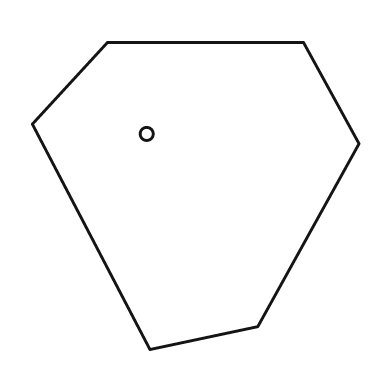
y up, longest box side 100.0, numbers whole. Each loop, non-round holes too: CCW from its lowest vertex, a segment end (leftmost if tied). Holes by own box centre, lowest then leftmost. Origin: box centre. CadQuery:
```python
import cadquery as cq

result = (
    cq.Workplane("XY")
    .moveTo(-14.0, -47.0)
    .lineTo(19.0, -40.0)
    .lineTo(50.0, 16.0)
    .lineTo(33.0, 47.0)
    .lineTo(-27.0, 47.0)
    .lineTo(-50.0, 22.0)
    .close()
    .moveTo(-15.0, 19.0)
    .circle(2.0)
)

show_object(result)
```